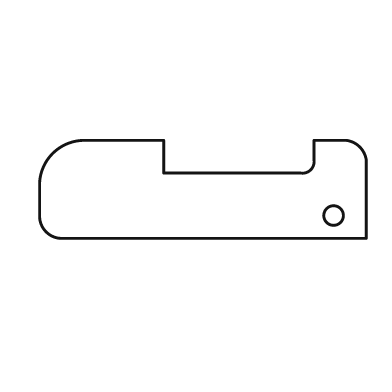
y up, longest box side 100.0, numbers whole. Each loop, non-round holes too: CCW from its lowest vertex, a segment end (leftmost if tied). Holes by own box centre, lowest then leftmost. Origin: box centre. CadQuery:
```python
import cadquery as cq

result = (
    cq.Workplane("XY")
    .moveTo(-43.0, -15.0)
    .lineTo(50.0, -15.0)
    .lineTo(50.0, 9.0)
    .threePointArc((48.0, 13.0), (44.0, 15.0))
    .lineTo(34.0, 15.0)
    .lineTo(34.0, 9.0)
    .threePointArc((33.0, 6.0), (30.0, 5.0))
    .lineTo(-12.0, 5.0)
    .lineTo(-12.0, 15.0)
    .lineTo(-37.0, 15.0)
    .threePointArc((-46.0, 11.0), (-50.0, 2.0))
    .lineTo(-50.0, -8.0)
    .threePointArc((-48.0, -13.0), (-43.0, -15.0))
    .close()
    .moveTo(40.0, -8.0)
    .circle(3.0)
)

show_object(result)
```